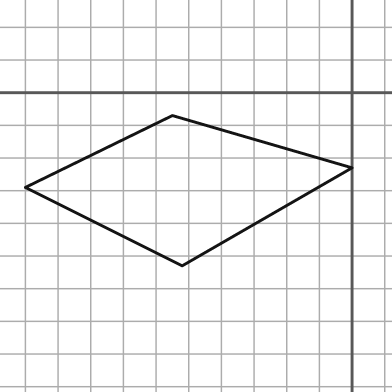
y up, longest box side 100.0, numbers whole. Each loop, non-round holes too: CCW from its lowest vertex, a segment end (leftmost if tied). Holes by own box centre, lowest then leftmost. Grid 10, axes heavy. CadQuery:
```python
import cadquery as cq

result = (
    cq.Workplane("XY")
    .moveTo(-52.0, -53.0)
    .lineTo(0.0, -23.0)
    .lineTo(-55.0, -7.0)
    .lineTo(-100.0, -29.0)
    .close()
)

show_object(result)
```